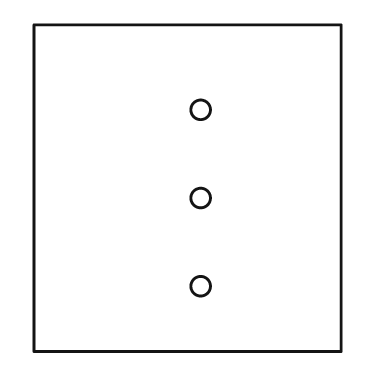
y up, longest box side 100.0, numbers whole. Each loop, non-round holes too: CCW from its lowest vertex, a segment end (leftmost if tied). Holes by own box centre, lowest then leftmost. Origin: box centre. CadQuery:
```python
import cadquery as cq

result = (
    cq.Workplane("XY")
    .moveTo(-47.0, -50.0)
    .lineTo(47.0, -50.0)
    .lineTo(47.0, 50.0)
    .lineTo(-47.0, 50.0)
    .close()
    .moveTo(4.0, -30.0)
    .circle(3.0)
    .moveTo(4.0, -3.0)
    .circle(3.0)
    .moveTo(4.0, 24.0)
    .circle(3.0)
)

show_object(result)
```